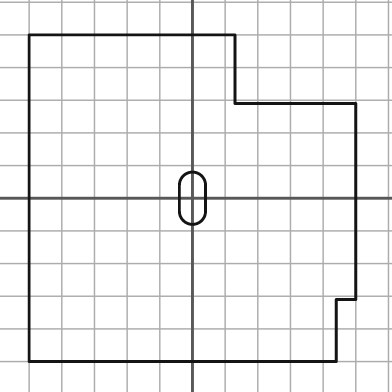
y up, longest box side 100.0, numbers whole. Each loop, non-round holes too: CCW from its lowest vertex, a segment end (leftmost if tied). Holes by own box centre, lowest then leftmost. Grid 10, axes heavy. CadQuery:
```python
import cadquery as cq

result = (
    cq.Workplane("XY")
    .moveTo(-50.0, -50.0)
    .lineTo(44.0, -50.0)
    .lineTo(44.0, -31.0)
    .lineTo(50.0, -31.0)
    .lineTo(50.0, 29.0)
    .lineTo(13.0, 29.0)
    .lineTo(13.0, 50.0)
    .lineTo(-50.0, 50.0)
    .close()
    .moveTo(-4.0, -4.0)
    .threePointArc((0.0, -8.0), (4.0, -4.0))
    .lineTo(4.0, 4.0)
    .threePointArc((0.0, 8.0), (-4.0, 4.0))
    .close()
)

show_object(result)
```